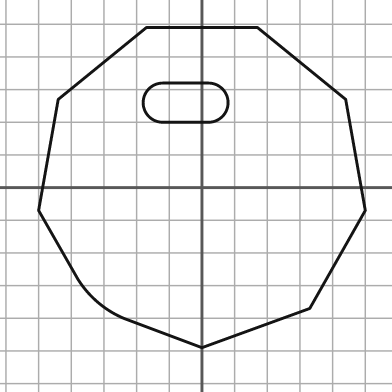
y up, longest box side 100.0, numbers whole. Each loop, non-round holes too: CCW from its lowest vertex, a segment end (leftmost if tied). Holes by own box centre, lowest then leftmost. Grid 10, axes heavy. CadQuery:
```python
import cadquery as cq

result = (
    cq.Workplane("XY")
    .moveTo(0.0, -49.0)
    .lineTo(33.0, -37.0)
    .lineTo(50.0, -7.0)
    .lineTo(44.0, 27.0)
    .lineTo(17.0, 49.0)
    .lineTo(-17.0, 49.0)
    .lineTo(-44.0, 27.0)
    .lineTo(-50.0, -7.0)
    .lineTo(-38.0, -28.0)
    .threePointArc((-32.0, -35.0), (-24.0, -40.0))
    .close()
    .moveTo(-12.0, 20.0)
    .lineTo(2.0, 20.0)
    .threePointArc((8.0, 26.0), (2.0, 32.0))
    .lineTo(-12.0, 32.0)
    .threePointArc((-18.0, 26.0), (-12.0, 20.0))
    .close()
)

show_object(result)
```